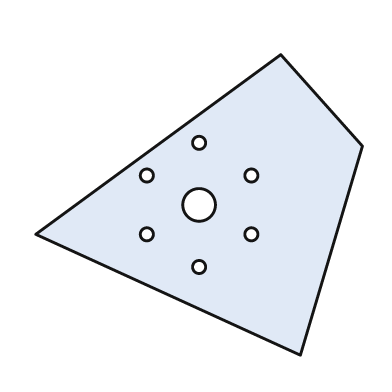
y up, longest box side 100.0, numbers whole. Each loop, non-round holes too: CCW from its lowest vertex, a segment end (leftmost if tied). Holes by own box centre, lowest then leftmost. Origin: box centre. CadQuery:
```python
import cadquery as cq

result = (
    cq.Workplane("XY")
    .moveTo(31.0, -46.0)
    .lineTo(50.0, 18.0)
    .lineTo(25.0, 46.0)
    .lineTo(-50.0, -9.0)
    .close()
    .moveTo(0.0, -19.0)
    .circle(2.0)
    .moveTo(-16.0, -9.0)
    .circle(2.0)
    .moveTo(16.0, -9.0)
    .circle(2.0)
    .moveTo(0.0, 0.0)
    .circle(5.0)
    .moveTo(-16.0, 9.0)
    .circle(2.0)
    .moveTo(16.0, 9.0)
    .circle(2.0)
    .moveTo(0.0, 19.0)
    .circle(2.0)
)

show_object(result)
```